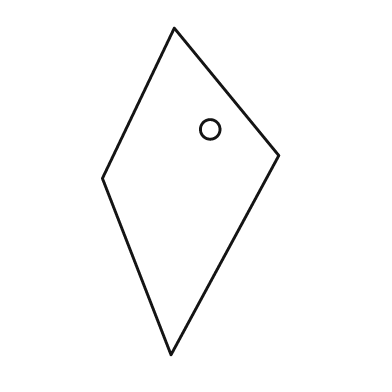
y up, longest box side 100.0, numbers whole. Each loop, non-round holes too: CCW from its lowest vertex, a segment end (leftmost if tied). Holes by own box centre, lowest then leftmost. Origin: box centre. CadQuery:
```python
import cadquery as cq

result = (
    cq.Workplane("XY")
    .moveTo(-6.0, -50.0)
    .lineTo(27.0, 11.0)
    .lineTo(-5.0, 50.0)
    .lineTo(-27.0, 4.0)
    .close()
    .moveTo(6.0, 19.0)
    .circle(3.0)
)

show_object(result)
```